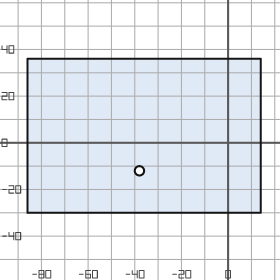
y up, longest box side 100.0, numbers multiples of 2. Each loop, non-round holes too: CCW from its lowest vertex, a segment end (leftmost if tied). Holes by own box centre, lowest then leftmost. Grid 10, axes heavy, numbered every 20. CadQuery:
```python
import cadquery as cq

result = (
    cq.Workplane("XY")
    .moveTo(-86.0, -30.0)
    .lineTo(14.0, -30.0)
    .lineTo(14.0, 36.0)
    .lineTo(-86.0, 36.0)
    .close()
    .moveTo(-38.0, -12.0)
    .circle(2.0)
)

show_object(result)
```